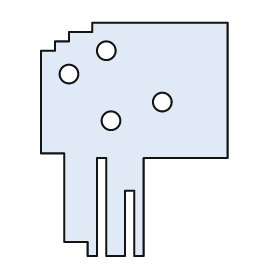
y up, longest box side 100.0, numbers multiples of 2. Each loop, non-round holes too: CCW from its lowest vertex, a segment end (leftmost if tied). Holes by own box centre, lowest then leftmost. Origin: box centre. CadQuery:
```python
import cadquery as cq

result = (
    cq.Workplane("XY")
    .moveTo(-20.0, -50.0)
    .lineTo(-16.0, -50.0)
    .lineTo(-16.0, -8.0)
    .lineTo(-12.0, -8.0)
    .lineTo(-12.0, -50.0)
    .lineTo(-4.0, -50.0)
    .lineTo(-4.0, -22.0)
    .lineTo(0.0, -22.0)
    .lineTo(0.0, -50.0)
    .lineTo(4.0, -50.0)
    .lineTo(4.0, -8.0)
    .lineTo(40.0, -8.0)
    .lineTo(40.0, 50.0)
    .lineTo(-18.0, 50.0)
    .lineTo(-18.0, 46.0)
    .lineTo(-28.0, 46.0)
    .lineTo(-28.0, 42.0)
    .lineTo(-34.0, 42.0)
    .lineTo(-34.0, 38.0)
    .lineTo(-40.0, 38.0)
    .lineTo(-40.0, -6.0)
    .lineTo(-30.0, -6.0)
    .lineTo(-30.0, -44.0)
    .lineTo(-20.0, -44.0)
    .close()
    .moveTo(-10.0, 8.0)
    .circle(4.0)
    .moveTo(12.0, 16.0)
    .circle(4.0)
    .moveTo(-28.0, 28.0)
    .circle(4.0)
    .moveTo(-12.0, 38.0)
    .circle(4.0)
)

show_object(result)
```